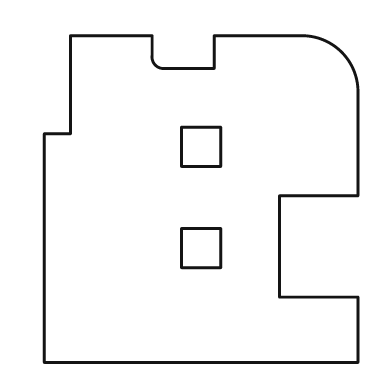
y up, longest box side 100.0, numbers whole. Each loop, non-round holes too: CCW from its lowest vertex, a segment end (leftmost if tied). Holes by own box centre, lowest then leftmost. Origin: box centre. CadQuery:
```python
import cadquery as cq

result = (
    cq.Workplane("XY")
    .moveTo(-48.0, -50.0)
    .lineTo(48.0, -50.0)
    .lineTo(48.0, -30.0)
    .lineTo(24.0, -30.0)
    .lineTo(24.0, 1.0)
    .lineTo(48.0, 1.0)
    .lineTo(48.0, 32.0)
    .threePointArc((43.0, 45.0), (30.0, 50.0))
    .lineTo(4.0, 50.0)
    .lineTo(4.0, 40.0)
    .lineTo(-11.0, 40.0)
    .threePointArc((-14.0, 41.0), (-15.0, 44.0))
    .lineTo(-15.0, 50.0)
    .lineTo(-40.0, 50.0)
    .lineTo(-40.0, 20.0)
    .lineTo(-48.0, 20.0)
    .close()
    .moveTo(-6.0, -21.0)
    .lineTo(6.0, -21.0)
    .lineTo(6.0, -9.0)
    .lineTo(-6.0, -9.0)
    .close()
    .moveTo(-6.0, 10.0)
    .lineTo(6.0, 10.0)
    .lineTo(6.0, 22.0)
    .lineTo(-6.0, 22.0)
    .close()
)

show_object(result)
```